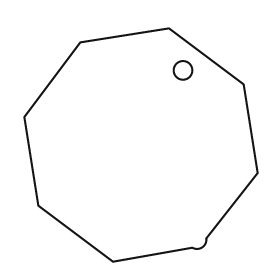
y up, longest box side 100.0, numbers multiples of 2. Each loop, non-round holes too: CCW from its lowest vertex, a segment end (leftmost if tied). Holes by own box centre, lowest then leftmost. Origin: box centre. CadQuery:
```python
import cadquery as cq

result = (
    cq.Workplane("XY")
    .moveTo(-12.0, -50.0)
    .lineTo(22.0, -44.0)
    .threePointArc((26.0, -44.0), (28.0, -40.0))
    .lineTo(50.0, -12.0)
    .lineTo(44.0, 26.0)
    .lineTo(12.0, 50.0)
    .lineTo(-26.0, 44.0)
    .lineTo(-50.0, 12.0)
    .lineTo(-44.0, -26.0)
    .close()
    .moveTo(18.0, 32.0)
    .circle(4.0)
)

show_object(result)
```